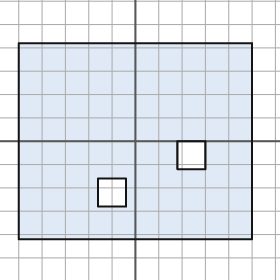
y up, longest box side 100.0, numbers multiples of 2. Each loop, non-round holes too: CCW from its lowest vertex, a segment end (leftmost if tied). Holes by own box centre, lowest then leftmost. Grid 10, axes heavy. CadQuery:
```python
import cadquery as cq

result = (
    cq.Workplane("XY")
    .moveTo(-50.0, -42.0)
    .lineTo(50.0, -42.0)
    .lineTo(50.0, 42.0)
    .lineTo(-50.0, 42.0)
    .close()
    .moveTo(-16.0, -28.0)
    .lineTo(-4.0, -28.0)
    .lineTo(-4.0, -16.0)
    .lineTo(-16.0, -16.0)
    .close()
    .moveTo(18.0, -12.0)
    .lineTo(30.0, -12.0)
    .lineTo(30.0, 0.0)
    .lineTo(18.0, 0.0)
    .close()
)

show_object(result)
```